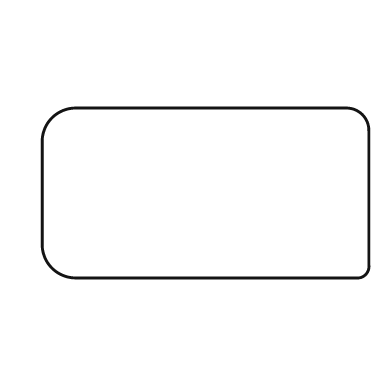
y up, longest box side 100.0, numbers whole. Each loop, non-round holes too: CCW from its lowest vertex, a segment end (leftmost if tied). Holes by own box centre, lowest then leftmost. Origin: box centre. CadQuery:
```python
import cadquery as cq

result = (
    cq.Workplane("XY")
    .moveTo(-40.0, -26.0)
    .lineTo(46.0, -26.0)
    .threePointArc((49.0, -25.0), (50.0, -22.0))
    .lineTo(50.0, 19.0)
    .threePointArc((48.0, 24.0), (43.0, 26.0))
    .lineTo(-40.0, 26.0)
    .threePointArc((-47.0, 23.0), (-50.0, 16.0))
    .lineTo(-50.0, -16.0)
    .threePointArc((-47.0, -23.0), (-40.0, -26.0))
    .close()
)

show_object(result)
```